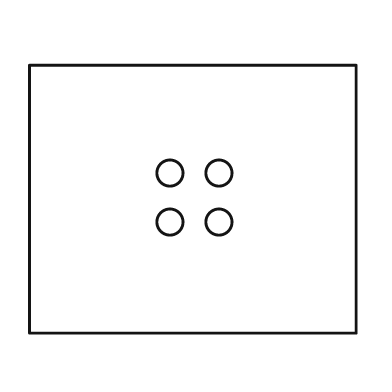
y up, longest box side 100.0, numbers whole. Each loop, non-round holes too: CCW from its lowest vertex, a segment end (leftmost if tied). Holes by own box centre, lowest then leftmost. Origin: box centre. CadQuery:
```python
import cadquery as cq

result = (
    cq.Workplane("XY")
    .moveTo(-50.0, -41.0)
    .lineTo(50.0, -41.0)
    .lineTo(50.0, 41.0)
    .lineTo(-50.0, 41.0)
    .close()
    .moveTo(-7.0, -7.0)
    .circle(4.0)
    .moveTo(8.0, -7.0)
    .circle(4.0)
    .moveTo(-7.0, 8.0)
    .circle(4.0)
    .moveTo(8.0, 8.0)
    .circle(4.0)
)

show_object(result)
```